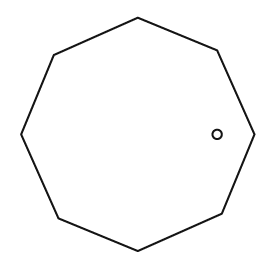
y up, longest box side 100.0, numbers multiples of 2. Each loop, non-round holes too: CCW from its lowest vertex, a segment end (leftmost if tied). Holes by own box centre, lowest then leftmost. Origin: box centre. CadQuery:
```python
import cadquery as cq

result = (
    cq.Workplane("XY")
    .moveTo(0.0, -50.0)
    .lineTo(36.0, -34.0)
    .lineTo(50.0, 0.0)
    .lineTo(34.0, 36.0)
    .lineTo(0.0, 50.0)
    .lineTo(-36.0, 34.0)
    .lineTo(-50.0, 0.0)
    .lineTo(-34.0, -36.0)
    .close()
    .moveTo(34.0, 0.0)
    .circle(2.0)
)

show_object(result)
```